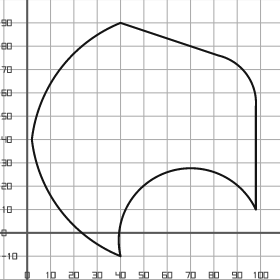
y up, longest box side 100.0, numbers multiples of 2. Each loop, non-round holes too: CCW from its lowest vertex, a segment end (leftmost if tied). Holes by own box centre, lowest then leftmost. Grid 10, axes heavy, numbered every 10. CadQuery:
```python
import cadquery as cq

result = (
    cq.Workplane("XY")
    .moveTo(40.0, -10.0)
    .threePointArc((60.0, 26.0), (98.0, 10.0))
    .lineTo(98.0, 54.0)
    .threePointArc((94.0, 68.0), (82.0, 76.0))
    .lineTo(40.0, 90.0)
    .threePointArc((14.0, 70.0), (2.0, 40.0))
    .threePointArc((14.0, 10.0), (40.0, -10.0))
    .close()
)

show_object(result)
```